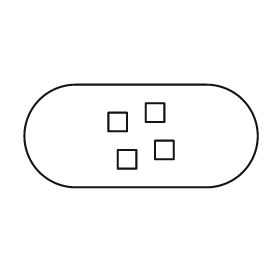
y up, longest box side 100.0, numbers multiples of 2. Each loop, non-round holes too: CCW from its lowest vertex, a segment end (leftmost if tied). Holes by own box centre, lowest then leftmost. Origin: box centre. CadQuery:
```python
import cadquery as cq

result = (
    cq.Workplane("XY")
    .moveTo(-28.0, -22.0)
    .lineTo(28.0, -22.0)
    .threePointArc((50.0, 0.0), (28.0, 22.0))
    .lineTo(-28.0, 22.0)
    .threePointArc((-50.0, 0.0), (-28.0, -22.0))
    .close()
    .moveTo(-10.0, -14.0)
    .lineTo(-2.0, -14.0)
    .lineTo(-2.0, -6.0)
    .lineTo(-10.0, -6.0)
    .close()
    .moveTo(6.0, -10.0)
    .lineTo(14.0, -10.0)
    .lineTo(14.0, -2.0)
    .lineTo(6.0, -2.0)
    .close()
    .moveTo(-14.0, 2.0)
    .lineTo(-6.0, 2.0)
    .lineTo(-6.0, 10.0)
    .lineTo(-14.0, 10.0)
    .close()
    .moveTo(2.0, 6.0)
    .lineTo(10.0, 6.0)
    .lineTo(10.0, 14.0)
    .lineTo(2.0, 14.0)
    .close()
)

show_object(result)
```